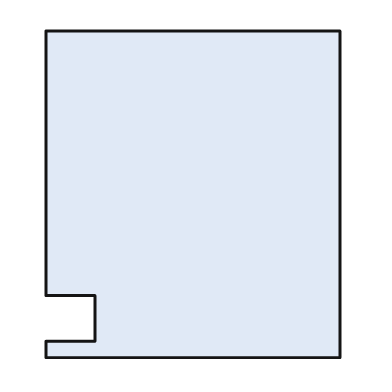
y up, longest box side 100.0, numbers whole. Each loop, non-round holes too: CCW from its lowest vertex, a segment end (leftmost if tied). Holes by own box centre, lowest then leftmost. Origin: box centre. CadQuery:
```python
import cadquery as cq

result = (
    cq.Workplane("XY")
    .moveTo(-45.0, -50.0)
    .lineTo(45.0, -50.0)
    .lineTo(45.0, 50.0)
    .lineTo(-45.0, 50.0)
    .lineTo(-45.0, -31.0)
    .lineTo(-30.0, -31.0)
    .lineTo(-30.0, -45.0)
    .lineTo(-45.0, -45.0)
    .close()
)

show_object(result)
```